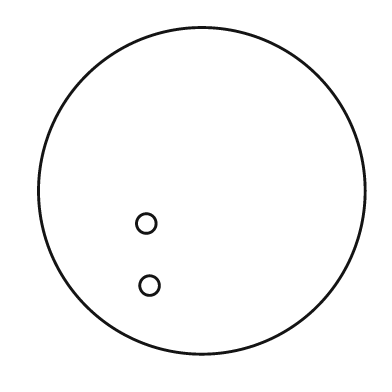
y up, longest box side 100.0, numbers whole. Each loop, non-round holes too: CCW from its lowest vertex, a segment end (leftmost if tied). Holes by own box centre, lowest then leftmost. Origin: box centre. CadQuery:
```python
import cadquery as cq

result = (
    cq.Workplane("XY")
    .moveTo(0.0, 0.0)
    .circle(50.0)
    .moveTo(-16.0, -29.0)
    .circle(3.0)
    .moveTo(-17.0, -10.0)
    .circle(3.0)
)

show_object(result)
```